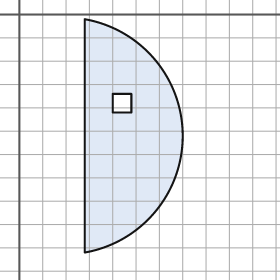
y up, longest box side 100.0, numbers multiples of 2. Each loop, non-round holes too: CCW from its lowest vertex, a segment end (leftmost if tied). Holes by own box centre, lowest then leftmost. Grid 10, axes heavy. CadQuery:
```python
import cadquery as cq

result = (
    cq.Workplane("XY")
    .moveTo(28.0, -102.0)
    .threePointArc((70.0, -52.0), (28.0, -2.0))
    .close()
    .moveTo(40.0, -42.0)
    .lineTo(48.0, -42.0)
    .lineTo(48.0, -34.0)
    .lineTo(40.0, -34.0)
    .close()
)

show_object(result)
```